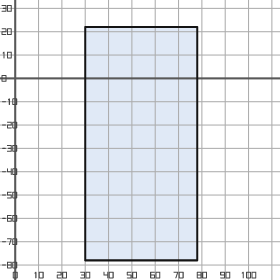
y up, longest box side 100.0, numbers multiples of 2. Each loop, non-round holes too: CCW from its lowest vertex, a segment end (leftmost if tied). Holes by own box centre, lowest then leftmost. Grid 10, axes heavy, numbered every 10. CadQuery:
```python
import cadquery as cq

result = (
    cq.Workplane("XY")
    .moveTo(30.0, -78.0)
    .lineTo(78.0, -78.0)
    .lineTo(78.0, 22.0)
    .lineTo(30.0, 22.0)
    .close()
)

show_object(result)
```